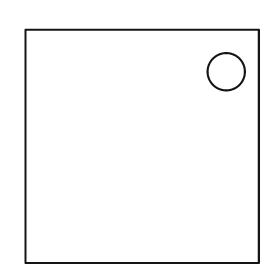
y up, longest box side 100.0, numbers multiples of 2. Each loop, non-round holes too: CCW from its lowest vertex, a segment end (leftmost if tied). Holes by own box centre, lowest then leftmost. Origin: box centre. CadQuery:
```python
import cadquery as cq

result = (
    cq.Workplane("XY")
    .moveTo(-50.0, -50.0)
    .lineTo(50.0, -50.0)
    .lineTo(50.0, 50.0)
    .lineTo(-50.0, 50.0)
    .close()
    .moveTo(36.0, 32.0)
    .circle(8.0)
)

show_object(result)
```